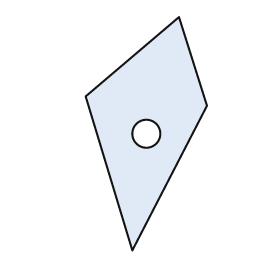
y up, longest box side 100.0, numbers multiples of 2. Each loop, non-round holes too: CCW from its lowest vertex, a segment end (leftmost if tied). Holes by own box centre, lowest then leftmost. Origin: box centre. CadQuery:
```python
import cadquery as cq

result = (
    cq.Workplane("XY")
    .moveTo(-6.0, -50.0)
    .lineTo(26.0, 12.0)
    .lineTo(14.0, 50.0)
    .lineTo(-26.0, 16.0)
    .close()
    .moveTo(0.0, 0.0)
    .circle(6.0)
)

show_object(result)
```